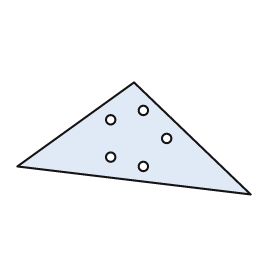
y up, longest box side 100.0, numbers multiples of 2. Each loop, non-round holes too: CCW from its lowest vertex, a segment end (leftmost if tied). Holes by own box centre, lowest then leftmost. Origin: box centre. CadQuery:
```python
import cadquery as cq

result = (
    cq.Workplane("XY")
    .moveTo(50.0, -24.0)
    .lineTo(0.0, 24.0)
    .lineTo(-50.0, -12.0)
    .close()
    .moveTo(4.0, -12.0)
    .circle(2.0)
    .moveTo(-10.0, -8.0)
    .circle(2.0)
    .moveTo(14.0, 0.0)
    .circle(2.0)
    .moveTo(-10.0, 8.0)
    .circle(2.0)
    .moveTo(4.0, 12.0)
    .circle(2.0)
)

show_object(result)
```